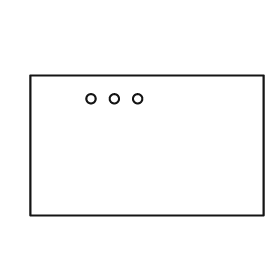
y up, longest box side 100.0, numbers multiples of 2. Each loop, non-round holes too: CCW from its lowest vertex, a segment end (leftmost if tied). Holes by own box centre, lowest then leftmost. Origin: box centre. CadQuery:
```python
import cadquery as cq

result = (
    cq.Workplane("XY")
    .moveTo(-50.0, -30.0)
    .lineTo(50.0, -30.0)
    .lineTo(50.0, 30.0)
    .lineTo(-50.0, 30.0)
    .close()
    .moveTo(-24.0, 20.0)
    .circle(2.0)
    .moveTo(-14.0, 20.0)
    .circle(2.0)
    .moveTo(-4.0, 20.0)
    .circle(2.0)
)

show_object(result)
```